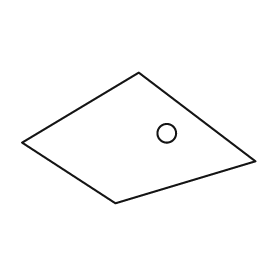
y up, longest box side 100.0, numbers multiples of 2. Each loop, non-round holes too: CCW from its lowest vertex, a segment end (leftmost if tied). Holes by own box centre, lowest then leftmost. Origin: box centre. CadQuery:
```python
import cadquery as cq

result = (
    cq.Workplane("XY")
    .moveTo(-10.0, -28.0)
    .lineTo(50.0, -10.0)
    .lineTo(0.0, 28.0)
    .lineTo(-50.0, -2.0)
    .close()
    .moveTo(12.0, 2.0)
    .circle(4.0)
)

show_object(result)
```